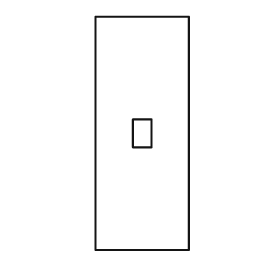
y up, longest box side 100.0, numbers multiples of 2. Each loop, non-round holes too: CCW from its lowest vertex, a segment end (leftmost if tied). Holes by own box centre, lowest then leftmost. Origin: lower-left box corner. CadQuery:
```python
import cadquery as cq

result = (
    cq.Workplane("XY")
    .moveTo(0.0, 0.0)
    .lineTo(40.0, 0.0)
    .lineTo(40.0, 100.0)
    .lineTo(0.0, 100.0)
    .close()
    .moveTo(16.0, 44.0)
    .lineTo(24.0, 44.0)
    .lineTo(24.0, 56.0)
    .lineTo(16.0, 56.0)
    .close()
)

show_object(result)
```